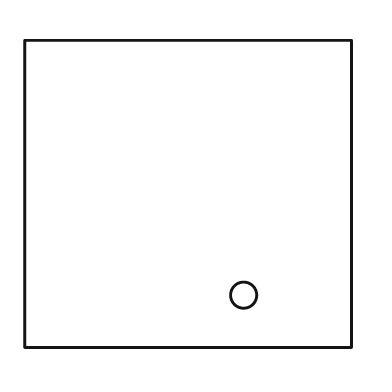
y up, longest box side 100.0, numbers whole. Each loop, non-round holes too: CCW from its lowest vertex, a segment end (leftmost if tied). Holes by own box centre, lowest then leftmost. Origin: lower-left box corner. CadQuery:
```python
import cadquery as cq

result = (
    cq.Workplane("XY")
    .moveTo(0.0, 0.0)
    .lineTo(100.0, 0.0)
    .lineTo(100.0, 94.0)
    .lineTo(0.0, 94.0)
    .close()
    .moveTo(67.0, 16.0)
    .circle(4.0)
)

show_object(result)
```